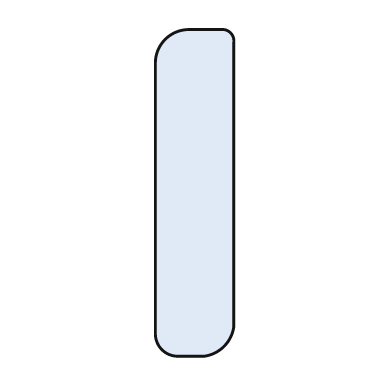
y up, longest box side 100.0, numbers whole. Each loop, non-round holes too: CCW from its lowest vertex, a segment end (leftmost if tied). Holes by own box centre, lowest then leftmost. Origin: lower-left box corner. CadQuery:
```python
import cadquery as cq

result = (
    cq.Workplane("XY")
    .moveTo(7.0, 0.0)
    .lineTo(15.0, 0.0)
    .threePointArc((21.0, 3.0), (24.0, 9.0))
    .lineTo(24.0, 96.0)
    .threePointArc((23.0, 99.0), (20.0, 100.0))
    .lineTo(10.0, 100.0)
    .threePointArc((3.0, 97.0), (0.0, 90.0))
    .lineTo(0.0, 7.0)
    .threePointArc((2.0, 2.0), (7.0, 0.0))
    .close()
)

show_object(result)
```